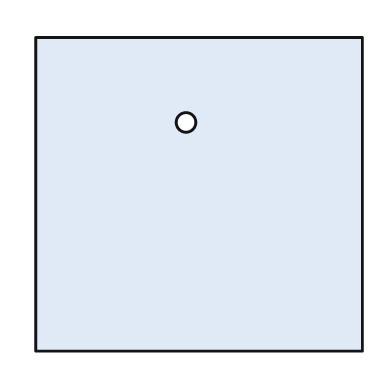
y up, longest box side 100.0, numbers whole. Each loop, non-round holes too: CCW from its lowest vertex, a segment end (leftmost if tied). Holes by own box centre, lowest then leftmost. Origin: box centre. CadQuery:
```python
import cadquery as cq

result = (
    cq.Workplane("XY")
    .moveTo(-50.0, -48.0)
    .lineTo(50.0, -48.0)
    .lineTo(50.0, 48.0)
    .lineTo(-50.0, 48.0)
    .close()
    .moveTo(-4.0, 22.0)
    .circle(3.0)
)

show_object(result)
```